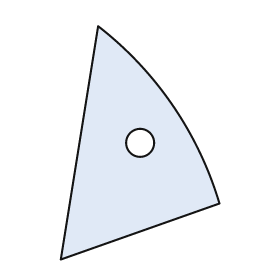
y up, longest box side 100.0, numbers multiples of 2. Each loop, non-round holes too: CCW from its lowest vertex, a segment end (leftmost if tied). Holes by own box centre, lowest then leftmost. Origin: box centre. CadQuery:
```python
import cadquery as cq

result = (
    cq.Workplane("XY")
    .moveTo(-34.0, -50.0)
    .lineTo(34.0, -26.0)
    .threePointArc((14.0, 16.0), (-18.0, 50.0))
    .close()
    .moveTo(0.0, 0.0)
    .circle(6.0)
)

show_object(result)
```